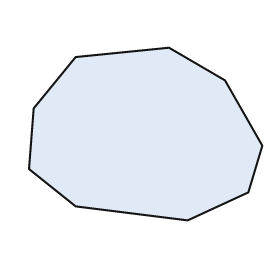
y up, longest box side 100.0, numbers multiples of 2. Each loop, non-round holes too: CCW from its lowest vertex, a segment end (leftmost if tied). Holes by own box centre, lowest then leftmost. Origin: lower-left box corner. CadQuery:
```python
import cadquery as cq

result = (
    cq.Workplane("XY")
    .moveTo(68.0, 0.0)
    .lineTo(94.0, 12.0)
    .lineTo(100.0, 32.0)
    .lineTo(84.0, 60.0)
    .lineTo(60.0, 74.0)
    .lineTo(20.0, 70.0)
    .lineTo(2.0, 48.0)
    .lineTo(0.0, 22.0)
    .lineTo(20.0, 6.0)
    .close()
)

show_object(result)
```